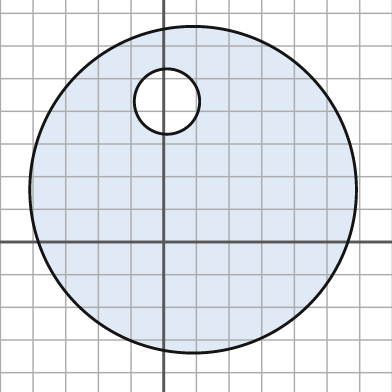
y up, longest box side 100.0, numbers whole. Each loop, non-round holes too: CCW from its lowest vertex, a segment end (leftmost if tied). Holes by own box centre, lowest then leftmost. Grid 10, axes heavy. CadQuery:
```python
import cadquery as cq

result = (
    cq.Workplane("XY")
    .moveTo(9.0, 16.0)
    .circle(50.0)
    .moveTo(1.0, 43.0)
    .circle(10.0)
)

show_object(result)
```